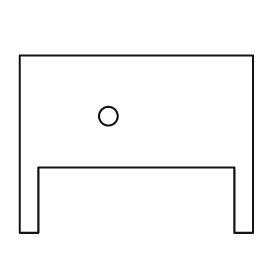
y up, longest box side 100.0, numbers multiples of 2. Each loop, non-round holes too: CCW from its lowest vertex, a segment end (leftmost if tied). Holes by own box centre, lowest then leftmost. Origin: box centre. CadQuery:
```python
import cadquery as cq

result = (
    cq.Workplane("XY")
    .moveTo(-50.0, -38.0)
    .lineTo(-42.0, -38.0)
    .lineTo(-42.0, -10.0)
    .lineTo(42.0, -10.0)
    .lineTo(42.0, -38.0)
    .lineTo(50.0, -38.0)
    .lineTo(50.0, 38.0)
    .lineTo(-50.0, 38.0)
    .close()
    .moveTo(-12.0, 12.0)
    .circle(4.0)
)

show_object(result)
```